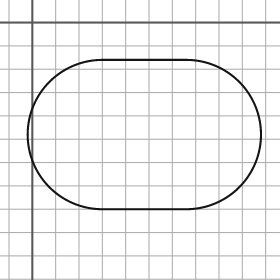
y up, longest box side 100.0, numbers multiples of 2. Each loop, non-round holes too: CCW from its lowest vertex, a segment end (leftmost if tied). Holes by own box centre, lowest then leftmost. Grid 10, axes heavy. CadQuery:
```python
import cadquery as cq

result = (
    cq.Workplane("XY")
    .moveTo(30.0, -80.0)
    .lineTo(66.0, -80.0)
    .threePointArc((98.0, -48.0), (66.0, -16.0))
    .lineTo(30.0, -16.0)
    .threePointArc((-2.0, -48.0), (30.0, -80.0))
    .close()
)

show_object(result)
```